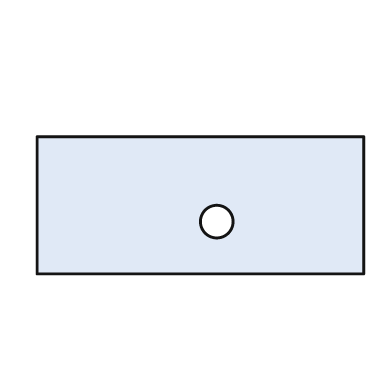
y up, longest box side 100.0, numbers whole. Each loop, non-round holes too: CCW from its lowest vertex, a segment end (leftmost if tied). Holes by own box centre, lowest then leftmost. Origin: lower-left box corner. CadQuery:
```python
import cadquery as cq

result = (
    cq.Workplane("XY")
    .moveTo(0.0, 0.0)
    .lineTo(100.0, 0.0)
    .lineTo(100.0, 42.0)
    .lineTo(0.0, 42.0)
    .close()
    .moveTo(55.0, 16.0)
    .circle(5.0)
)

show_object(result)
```